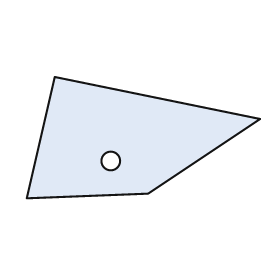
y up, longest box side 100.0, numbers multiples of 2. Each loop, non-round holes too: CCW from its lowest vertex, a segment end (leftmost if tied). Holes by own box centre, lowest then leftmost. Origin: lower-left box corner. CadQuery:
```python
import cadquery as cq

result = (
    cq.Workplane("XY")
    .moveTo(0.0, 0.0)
    .lineTo(52.0, 2.0)
    .lineTo(100.0, 34.0)
    .lineTo(12.0, 52.0)
    .close()
    .moveTo(36.0, 16.0)
    .circle(4.0)
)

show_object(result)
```